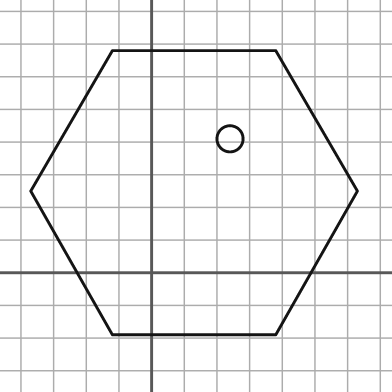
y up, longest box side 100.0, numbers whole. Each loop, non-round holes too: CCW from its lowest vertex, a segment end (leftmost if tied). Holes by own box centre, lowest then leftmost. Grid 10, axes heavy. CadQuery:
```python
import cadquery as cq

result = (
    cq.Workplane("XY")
    .moveTo(-12.0, -19.0)
    .lineTo(38.0, -19.0)
    .lineTo(63.0, 25.0)
    .lineTo(38.0, 68.0)
    .lineTo(-12.0, 68.0)
    .lineTo(-37.0, 25.0)
    .close()
    .moveTo(24.0, 41.0)
    .circle(4.0)
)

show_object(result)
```